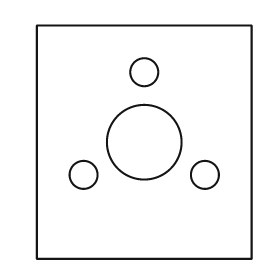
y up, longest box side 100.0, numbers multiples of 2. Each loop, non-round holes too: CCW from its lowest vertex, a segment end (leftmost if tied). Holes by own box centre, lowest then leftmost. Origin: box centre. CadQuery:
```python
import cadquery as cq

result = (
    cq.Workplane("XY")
    .moveTo(-46.0, -50.0)
    .lineTo(46.0, -50.0)
    .lineTo(46.0, 50.0)
    .lineTo(-46.0, 50.0)
    .close()
    .moveTo(-26.0, -14.0)
    .circle(6.0)
    .moveTo(26.0, -14.0)
    .circle(6.0)
    .moveTo(0.0, 0.0)
    .circle(16.0)
    .moveTo(0.0, 30.0)
    .circle(6.0)
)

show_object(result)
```